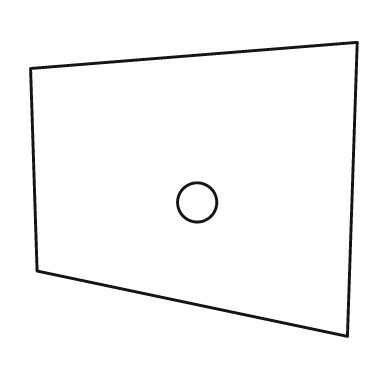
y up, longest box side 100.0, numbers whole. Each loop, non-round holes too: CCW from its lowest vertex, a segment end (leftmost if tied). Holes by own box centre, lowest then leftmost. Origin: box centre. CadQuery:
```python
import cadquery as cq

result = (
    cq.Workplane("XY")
    .moveTo(47.0, -45.0)
    .lineTo(50.0, 45.0)
    .lineTo(-50.0, 37.0)
    .lineTo(-48.0, -25.0)
    .close()
    .moveTo(1.0, -4.0)
    .circle(6.0)
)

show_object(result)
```